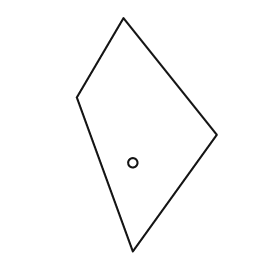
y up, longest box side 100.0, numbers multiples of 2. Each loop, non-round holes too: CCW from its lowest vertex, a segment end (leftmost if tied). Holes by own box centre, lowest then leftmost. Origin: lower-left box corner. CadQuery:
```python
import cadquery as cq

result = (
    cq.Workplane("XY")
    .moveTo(24.0, 0.0)
    .lineTo(60.0, 50.0)
    .lineTo(20.0, 100.0)
    .lineTo(0.0, 66.0)
    .close()
    .moveTo(24.0, 38.0)
    .circle(2.0)
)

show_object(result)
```